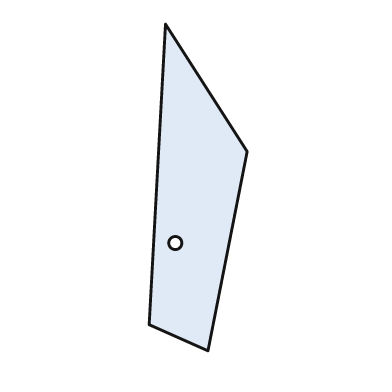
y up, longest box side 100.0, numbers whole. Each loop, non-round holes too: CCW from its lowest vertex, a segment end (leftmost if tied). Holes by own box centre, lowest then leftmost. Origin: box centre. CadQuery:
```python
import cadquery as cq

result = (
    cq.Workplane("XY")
    .moveTo(3.0, -50.0)
    .lineTo(15.0, 11.0)
    .lineTo(-10.0, 50.0)
    .lineTo(-15.0, -42.0)
    .close()
    .moveTo(-7.0, -17.0)
    .circle(2.0)
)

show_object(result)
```